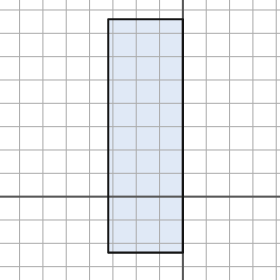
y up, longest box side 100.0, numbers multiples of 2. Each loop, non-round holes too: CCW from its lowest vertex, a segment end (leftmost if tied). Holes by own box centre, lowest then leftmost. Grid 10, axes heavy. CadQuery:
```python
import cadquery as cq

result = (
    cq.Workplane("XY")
    .moveTo(-32.0, -24.0)
    .lineTo(0.0, -24.0)
    .lineTo(0.0, 76.0)
    .lineTo(-32.0, 76.0)
    .close()
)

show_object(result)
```